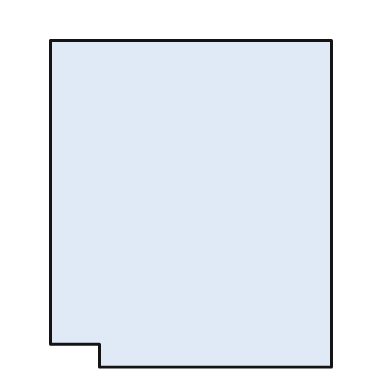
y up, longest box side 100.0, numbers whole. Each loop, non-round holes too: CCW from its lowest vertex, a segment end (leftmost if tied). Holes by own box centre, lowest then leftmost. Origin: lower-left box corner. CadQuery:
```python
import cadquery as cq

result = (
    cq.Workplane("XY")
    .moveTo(15.0, 0.0)
    .lineTo(86.0, 0.0)
    .lineTo(86.0, 100.0)
    .lineTo(0.0, 100.0)
    .lineTo(0.0, 7.0)
    .lineTo(15.0, 7.0)
    .close()
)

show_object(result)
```